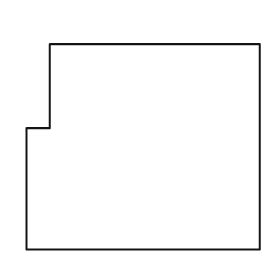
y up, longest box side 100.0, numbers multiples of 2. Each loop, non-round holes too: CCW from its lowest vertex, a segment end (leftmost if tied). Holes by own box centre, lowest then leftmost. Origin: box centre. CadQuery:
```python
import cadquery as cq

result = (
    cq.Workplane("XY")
    .moveTo(-50.0, -44.0)
    .lineTo(50.0, -44.0)
    .lineTo(50.0, 44.0)
    .lineTo(-40.0, 44.0)
    .lineTo(-40.0, 8.0)
    .lineTo(-50.0, 8.0)
    .close()
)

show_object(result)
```